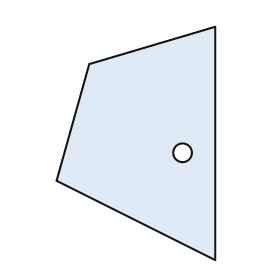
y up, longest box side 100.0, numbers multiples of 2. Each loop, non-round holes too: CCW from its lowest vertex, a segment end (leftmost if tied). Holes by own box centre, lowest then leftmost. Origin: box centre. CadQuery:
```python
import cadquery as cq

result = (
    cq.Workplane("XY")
    .moveTo(34.0, -50.0)
    .lineTo(34.0, 50.0)
    .lineTo(-20.0, 34.0)
    .lineTo(-34.0, -16.0)
    .close()
    .moveTo(20.0, -4.0)
    .circle(4.0)
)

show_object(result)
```